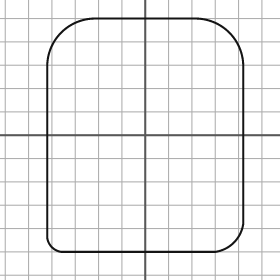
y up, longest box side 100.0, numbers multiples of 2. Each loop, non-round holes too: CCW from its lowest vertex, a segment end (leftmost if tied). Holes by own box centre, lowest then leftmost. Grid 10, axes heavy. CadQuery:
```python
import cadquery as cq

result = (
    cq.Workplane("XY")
    .moveTo(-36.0, -50.0)
    .lineTo(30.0, -50.0)
    .threePointArc((38.0, -46.0), (42.0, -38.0))
    .lineTo(42.0, 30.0)
    .threePointArc((36.0, 44.0), (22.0, 50.0))
    .lineTo(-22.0, 50.0)
    .threePointArc((-36.0, 44.0), (-42.0, 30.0))
    .lineTo(-42.0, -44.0)
    .threePointArc((-40.0, -48.0), (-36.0, -50.0))
    .close()
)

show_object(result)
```